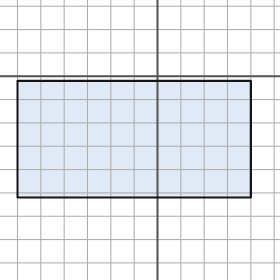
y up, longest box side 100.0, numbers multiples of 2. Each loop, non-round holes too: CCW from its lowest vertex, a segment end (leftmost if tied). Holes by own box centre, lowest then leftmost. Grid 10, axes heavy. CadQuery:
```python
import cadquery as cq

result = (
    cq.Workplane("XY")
    .moveTo(-60.0, -52.0)
    .lineTo(40.0, -52.0)
    .lineTo(40.0, -2.0)
    .lineTo(-60.0, -2.0)
    .close()
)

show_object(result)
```